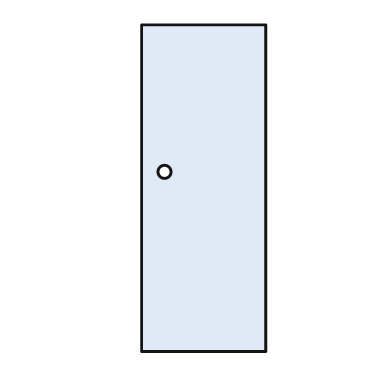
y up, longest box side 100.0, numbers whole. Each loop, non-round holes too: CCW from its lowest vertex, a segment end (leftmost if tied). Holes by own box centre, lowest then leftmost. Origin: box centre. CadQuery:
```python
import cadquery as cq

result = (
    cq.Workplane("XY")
    .moveTo(-19.0, -50.0)
    .lineTo(19.0, -50.0)
    .lineTo(19.0, 50.0)
    .lineTo(-19.0, 50.0)
    .close()
    .moveTo(-12.0, 5.0)
    .circle(2.0)
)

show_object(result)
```